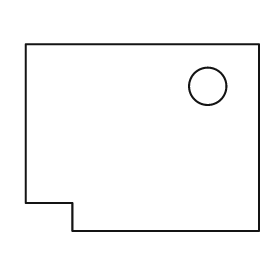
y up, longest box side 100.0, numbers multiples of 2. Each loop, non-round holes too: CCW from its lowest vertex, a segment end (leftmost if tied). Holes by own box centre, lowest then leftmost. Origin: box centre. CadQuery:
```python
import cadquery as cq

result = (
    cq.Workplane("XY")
    .moveTo(-30.0, -40.0)
    .lineTo(50.0, -40.0)
    .lineTo(50.0, 40.0)
    .lineTo(-50.0, 40.0)
    .lineTo(-50.0, -28.0)
    .lineTo(-30.0, -28.0)
    .close()
    .moveTo(28.0, 22.0)
    .circle(8.0)
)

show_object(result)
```